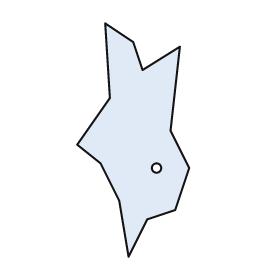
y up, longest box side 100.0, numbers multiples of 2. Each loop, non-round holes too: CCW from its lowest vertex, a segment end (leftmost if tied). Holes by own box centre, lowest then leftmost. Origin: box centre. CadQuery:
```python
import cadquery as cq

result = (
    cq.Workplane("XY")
    .moveTo(-2.0, -50.0)
    .lineTo(6.0, -34.0)
    .lineTo(18.0, -30.0)
    .lineTo(24.0, -12.0)
    .lineTo(16.0, 4.0)
    .lineTo(20.0, 40.0)
    .lineTo(4.0, 30.0)
    .lineTo(0.0, 42.0)
    .lineTo(-12.0, 50.0)
    .lineTo(-10.0, 18.0)
    .lineTo(-24.0, -2.0)
    .lineTo(-14.0, -10.0)
    .lineTo(-6.0, -26.0)
    .close()
    .moveTo(10.0, -12.0)
    .circle(2.0)
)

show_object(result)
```